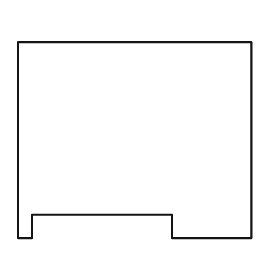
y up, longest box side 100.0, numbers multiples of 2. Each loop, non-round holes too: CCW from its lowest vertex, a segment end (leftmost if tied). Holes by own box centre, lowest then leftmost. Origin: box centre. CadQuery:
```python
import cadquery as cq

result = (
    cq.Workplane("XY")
    .moveTo(-50.0, -42.0)
    .lineTo(-44.0, -42.0)
    .lineTo(-44.0, -32.0)
    .lineTo(16.0, -32.0)
    .lineTo(16.0, -42.0)
    .lineTo(50.0, -42.0)
    .lineTo(50.0, 42.0)
    .lineTo(-50.0, 42.0)
    .close()
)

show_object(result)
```